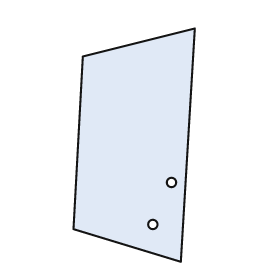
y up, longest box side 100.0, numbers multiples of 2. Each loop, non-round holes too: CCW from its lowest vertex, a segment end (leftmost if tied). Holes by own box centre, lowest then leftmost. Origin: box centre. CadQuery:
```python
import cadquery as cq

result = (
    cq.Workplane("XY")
    .moveTo(20.0, -50.0)
    .lineTo(26.0, 50.0)
    .lineTo(-22.0, 38.0)
    .lineTo(-26.0, -36.0)
    .close()
    .moveTo(8.0, -34.0)
    .circle(2.0)
    .moveTo(16.0, -16.0)
    .circle(2.0)
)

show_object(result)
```